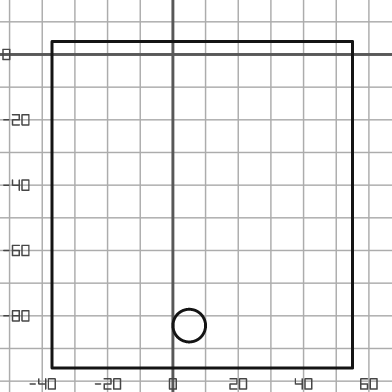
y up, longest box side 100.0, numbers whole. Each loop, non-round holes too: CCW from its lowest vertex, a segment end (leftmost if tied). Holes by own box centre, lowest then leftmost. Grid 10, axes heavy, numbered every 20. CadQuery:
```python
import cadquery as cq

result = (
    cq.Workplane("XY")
    .moveTo(-37.0, -96.0)
    .lineTo(55.0, -96.0)
    .lineTo(55.0, 4.0)
    .lineTo(-37.0, 4.0)
    .close()
    .moveTo(5.0, -83.0)
    .circle(5.0)
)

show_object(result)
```